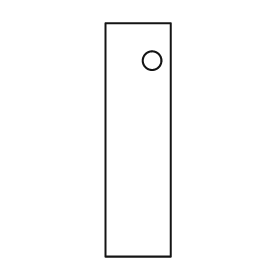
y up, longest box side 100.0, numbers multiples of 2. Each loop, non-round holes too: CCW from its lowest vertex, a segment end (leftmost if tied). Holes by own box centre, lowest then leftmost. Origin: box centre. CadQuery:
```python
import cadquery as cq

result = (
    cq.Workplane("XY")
    .moveTo(-14.0, -50.0)
    .lineTo(14.0, -50.0)
    .lineTo(14.0, 50.0)
    .lineTo(-14.0, 50.0)
    .close()
    .moveTo(6.0, 34.0)
    .circle(4.0)
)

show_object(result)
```